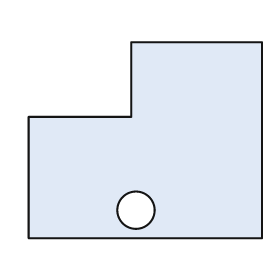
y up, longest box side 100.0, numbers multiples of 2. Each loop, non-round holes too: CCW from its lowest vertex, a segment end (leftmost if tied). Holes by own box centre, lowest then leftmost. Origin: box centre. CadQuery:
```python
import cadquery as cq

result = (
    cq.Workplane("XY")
    .moveTo(-50.0, -42.0)
    .lineTo(50.0, -42.0)
    .lineTo(50.0, 42.0)
    .lineTo(-6.0, 42.0)
    .lineTo(-6.0, 10.0)
    .lineTo(-50.0, 10.0)
    .close()
    .moveTo(-4.0, -30.0)
    .circle(8.0)
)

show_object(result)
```